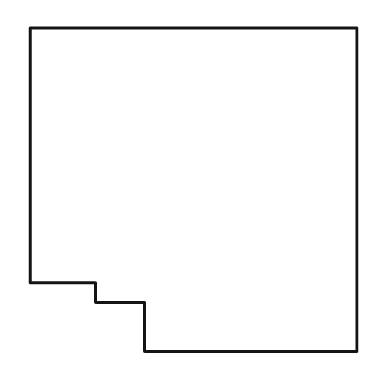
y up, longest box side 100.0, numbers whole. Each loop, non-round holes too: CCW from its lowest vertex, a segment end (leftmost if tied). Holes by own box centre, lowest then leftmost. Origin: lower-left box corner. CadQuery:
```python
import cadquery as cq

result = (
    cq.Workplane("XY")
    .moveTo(35.0, 0.0)
    .lineTo(100.0, 0.0)
    .lineTo(100.0, 99.0)
    .lineTo(0.0, 99.0)
    .lineTo(0.0, 21.0)
    .lineTo(20.0, 21.0)
    .lineTo(20.0, 15.0)
    .lineTo(35.0, 15.0)
    .close()
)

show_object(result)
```